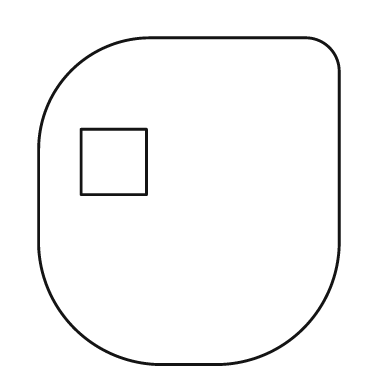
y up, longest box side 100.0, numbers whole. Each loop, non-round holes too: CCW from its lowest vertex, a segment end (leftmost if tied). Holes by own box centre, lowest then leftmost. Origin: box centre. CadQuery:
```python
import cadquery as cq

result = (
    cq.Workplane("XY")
    .moveTo(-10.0, -50.0)
    .lineTo(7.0, -50.0)
    .threePointArc((35.0, -39.0), (46.0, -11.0))
    .lineTo(46.0, 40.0)
    .threePointArc((43.0, 47.0), (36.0, 50.0))
    .lineTo(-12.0, 50.0)
    .threePointArc((-36.0, 40.0), (-46.0, 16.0))
    .lineTo(-46.0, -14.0)
    .threePointArc((-35.0, -39.0), (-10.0, -50.0))
    .close()
    .moveTo(-33.0, 2.0)
    .lineTo(-13.0, 2.0)
    .lineTo(-13.0, 22.0)
    .lineTo(-33.0, 22.0)
    .close()
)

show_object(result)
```